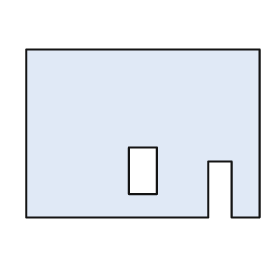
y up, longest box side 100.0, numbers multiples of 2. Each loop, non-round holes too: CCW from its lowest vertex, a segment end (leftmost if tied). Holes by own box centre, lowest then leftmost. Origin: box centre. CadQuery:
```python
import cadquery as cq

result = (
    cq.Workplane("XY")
    .moveTo(-50.0, -36.0)
    .lineTo(28.0, -36.0)
    .lineTo(28.0, -12.0)
    .lineTo(38.0, -12.0)
    .lineTo(38.0, -36.0)
    .lineTo(50.0, -36.0)
    .lineTo(50.0, 36.0)
    .lineTo(-50.0, 36.0)
    .close()
    .moveTo(-6.0, -26.0)
    .lineTo(6.0, -26.0)
    .lineTo(6.0, -6.0)
    .lineTo(-6.0, -6.0)
    .close()
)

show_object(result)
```